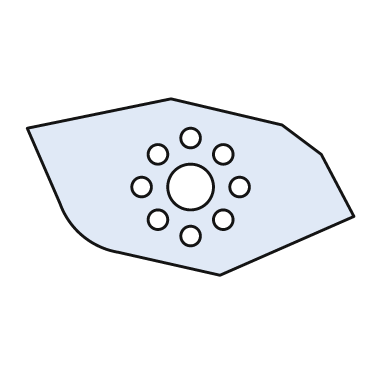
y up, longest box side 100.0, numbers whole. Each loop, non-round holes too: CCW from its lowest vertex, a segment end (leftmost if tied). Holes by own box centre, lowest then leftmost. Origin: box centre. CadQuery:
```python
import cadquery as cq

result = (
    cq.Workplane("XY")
    .moveTo(9.0, -27.0)
    .lineTo(50.0, -9.0)
    .lineTo(40.0, 10.0)
    .lineTo(28.0, 19.0)
    .lineTo(-6.0, 27.0)
    .lineTo(-50.0, 18.0)
    .lineTo(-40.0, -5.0)
    .threePointArc((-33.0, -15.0), (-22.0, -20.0))
    .close()
    .moveTo(0.0, -15.0)
    .circle(3.0)
    .moveTo(-10.0, -10.0)
    .circle(3.0)
    .moveTo(10.0, -10.0)
    .circle(3.0)
    .moveTo(-15.0, 0.0)
    .circle(3.0)
    .moveTo(0.0, 0.0)
    .circle(7.0)
    .moveTo(15.0, 0.0)
    .circle(3.0)
    .moveTo(-10.0, 10.0)
    .circle(3.0)
    .moveTo(10.0, 10.0)
    .circle(3.0)
    .moveTo(0.0, 15.0)
    .circle(3.0)
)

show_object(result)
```